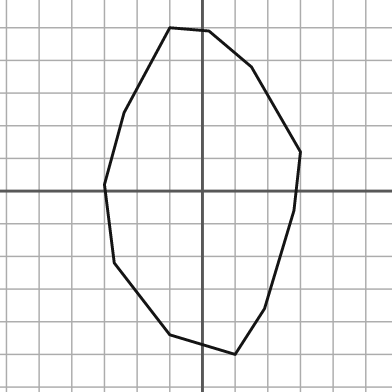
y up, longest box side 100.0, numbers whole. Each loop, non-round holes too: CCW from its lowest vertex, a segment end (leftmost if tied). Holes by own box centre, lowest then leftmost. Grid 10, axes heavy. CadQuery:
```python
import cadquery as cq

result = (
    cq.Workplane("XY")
    .moveTo(10.0, -50.0)
    .lineTo(19.0, -36.0)
    .lineTo(28.0, -6.0)
    .lineTo(30.0, 12.0)
    .lineTo(15.0, 38.0)
    .lineTo(2.0, 49.0)
    .lineTo(-10.0, 50.0)
    .lineTo(-24.0, 24.0)
    .lineTo(-30.0, 2.0)
    .lineTo(-27.0, -22.0)
    .lineTo(-10.0, -44.0)
    .close()
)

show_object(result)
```